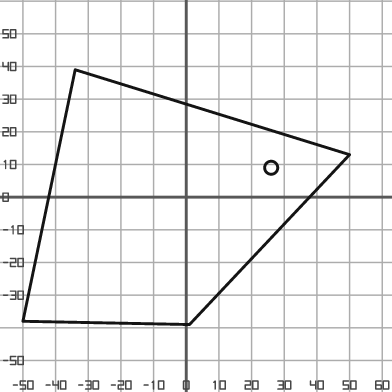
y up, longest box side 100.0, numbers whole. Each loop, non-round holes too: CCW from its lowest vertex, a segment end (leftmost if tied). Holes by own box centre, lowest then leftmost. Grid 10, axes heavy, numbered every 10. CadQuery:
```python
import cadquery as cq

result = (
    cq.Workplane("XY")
    .moveTo(1.0, -39.0)
    .lineTo(50.0, 13.0)
    .lineTo(-34.0, 39.0)
    .lineTo(-50.0, -38.0)
    .close()
    .moveTo(26.0, 9.0)
    .circle(2.0)
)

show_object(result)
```